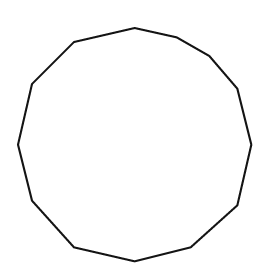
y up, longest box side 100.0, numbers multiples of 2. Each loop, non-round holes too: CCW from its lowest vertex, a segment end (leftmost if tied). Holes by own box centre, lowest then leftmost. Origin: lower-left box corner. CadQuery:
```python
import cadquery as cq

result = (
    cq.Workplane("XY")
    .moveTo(50.0, 0.0)
    .lineTo(74.0, 6.0)
    .lineTo(94.0, 24.0)
    .lineTo(100.0, 50.0)
    .lineTo(94.0, 74.0)
    .lineTo(82.0, 88.0)
    .lineTo(68.0, 96.0)
    .lineTo(50.0, 100.0)
    .lineTo(24.0, 94.0)
    .lineTo(6.0, 76.0)
    .lineTo(0.0, 50.0)
    .lineTo(6.0, 26.0)
    .lineTo(24.0, 6.0)
    .close()
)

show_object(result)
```